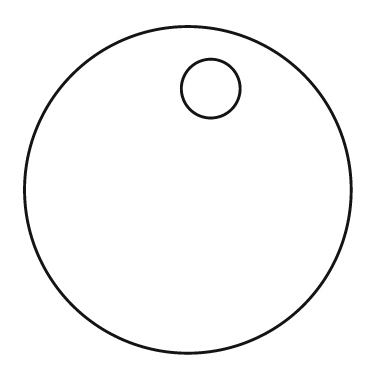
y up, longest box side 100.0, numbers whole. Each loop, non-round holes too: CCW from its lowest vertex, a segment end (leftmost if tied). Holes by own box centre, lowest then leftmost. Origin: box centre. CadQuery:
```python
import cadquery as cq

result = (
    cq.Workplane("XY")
    .moveTo(0.0, 0.0)
    .circle(50.0)
    .moveTo(7.0, 31.0)
    .circle(9.0)
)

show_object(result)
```